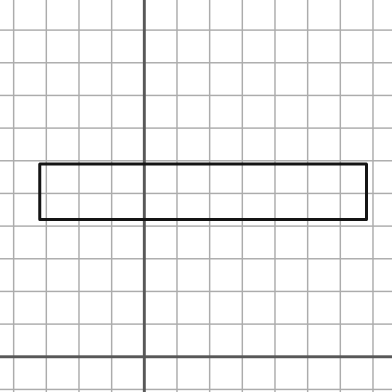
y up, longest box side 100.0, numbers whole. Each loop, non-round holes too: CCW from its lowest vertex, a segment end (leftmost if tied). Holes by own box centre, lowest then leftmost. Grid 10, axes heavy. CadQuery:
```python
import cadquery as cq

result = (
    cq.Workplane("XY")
    .moveTo(-32.0, 42.0)
    .lineTo(68.0, 42.0)
    .lineTo(68.0, 59.0)
    .lineTo(-32.0, 59.0)
    .close()
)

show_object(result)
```